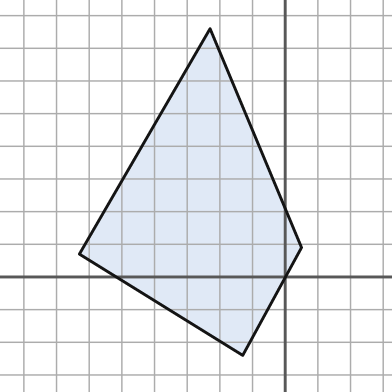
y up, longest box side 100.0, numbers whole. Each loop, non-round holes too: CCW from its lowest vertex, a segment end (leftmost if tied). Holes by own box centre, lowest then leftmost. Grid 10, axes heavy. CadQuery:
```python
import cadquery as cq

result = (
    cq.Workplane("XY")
    .moveTo(-13.0, -24.0)
    .lineTo(5.0, 9.0)
    .lineTo(-23.0, 76.0)
    .lineTo(-63.0, 7.0)
    .close()
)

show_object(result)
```